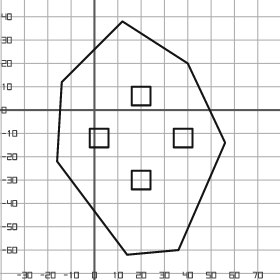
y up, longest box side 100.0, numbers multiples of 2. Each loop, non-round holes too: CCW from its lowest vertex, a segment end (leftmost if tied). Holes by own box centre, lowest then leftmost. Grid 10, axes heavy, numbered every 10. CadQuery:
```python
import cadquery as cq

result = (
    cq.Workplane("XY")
    .moveTo(14.0, -62.0)
    .lineTo(36.0, -60.0)
    .lineTo(56.0, -14.0)
    .lineTo(40.0, 20.0)
    .lineTo(12.0, 38.0)
    .lineTo(-14.0, 12.0)
    .lineTo(-16.0, -22.0)
    .close()
    .moveTo(16.0, -34.0)
    .lineTo(24.0, -34.0)
    .lineTo(24.0, -26.0)
    .lineTo(16.0, -26.0)
    .close()
    .moveTo(-2.0, -16.0)
    .lineTo(6.0, -16.0)
    .lineTo(6.0, -8.0)
    .lineTo(-2.0, -8.0)
    .close()
    .moveTo(34.0, -16.0)
    .lineTo(42.0, -16.0)
    .lineTo(42.0, -8.0)
    .lineTo(34.0, -8.0)
    .close()
    .moveTo(16.0, 2.0)
    .lineTo(24.0, 2.0)
    .lineTo(24.0, 10.0)
    .lineTo(16.0, 10.0)
    .close()
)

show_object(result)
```